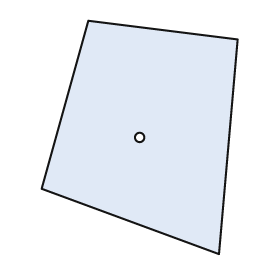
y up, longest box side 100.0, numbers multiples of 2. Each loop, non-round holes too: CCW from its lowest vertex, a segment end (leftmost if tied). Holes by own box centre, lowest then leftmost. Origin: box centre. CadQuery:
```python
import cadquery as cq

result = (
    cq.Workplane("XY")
    .moveTo(34.0, -50.0)
    .lineTo(42.0, 42.0)
    .lineTo(-22.0, 50.0)
    .lineTo(-42.0, -22.0)
    .close()
    .moveTo(0.0, 0.0)
    .circle(2.0)
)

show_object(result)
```